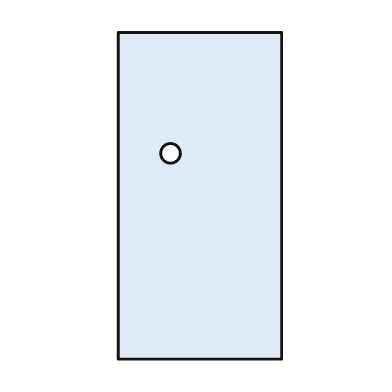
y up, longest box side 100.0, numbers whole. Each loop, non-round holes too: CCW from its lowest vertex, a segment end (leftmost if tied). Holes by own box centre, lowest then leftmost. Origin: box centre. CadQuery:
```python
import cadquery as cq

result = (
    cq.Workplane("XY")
    .moveTo(-25.0, -50.0)
    .lineTo(25.0, -50.0)
    .lineTo(25.0, 50.0)
    .lineTo(-25.0, 50.0)
    .close()
    .moveTo(-9.0, 13.0)
    .circle(3.0)
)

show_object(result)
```